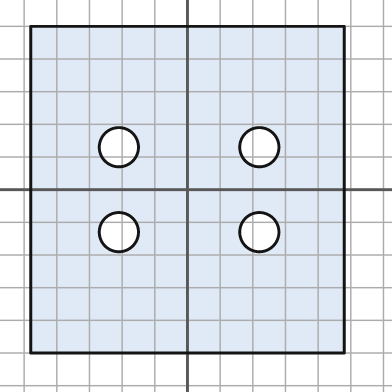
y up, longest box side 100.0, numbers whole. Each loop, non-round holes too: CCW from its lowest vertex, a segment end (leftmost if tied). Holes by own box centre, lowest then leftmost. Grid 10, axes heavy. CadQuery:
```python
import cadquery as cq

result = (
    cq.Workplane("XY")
    .moveTo(-48.0, -50.0)
    .lineTo(48.0, -50.0)
    .lineTo(48.0, 50.0)
    .lineTo(-48.0, 50.0)
    .close()
    .moveTo(-21.0, -13.0)
    .circle(6.0)
    .moveTo(22.0, -13.0)
    .circle(6.0)
    .moveTo(-21.0, 13.0)
    .circle(6.0)
    .moveTo(22.0, 13.0)
    .circle(6.0)
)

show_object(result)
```